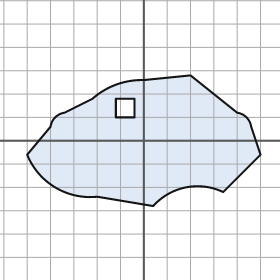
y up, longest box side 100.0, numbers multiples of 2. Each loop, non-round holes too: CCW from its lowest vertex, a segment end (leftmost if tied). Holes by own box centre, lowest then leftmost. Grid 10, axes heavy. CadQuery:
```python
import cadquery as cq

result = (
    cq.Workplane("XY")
    .moveTo(4.0, -28.0)
    .threePointArc((18.0, -20.0), (34.0, -22.0))
    .lineTo(50.0, -6.0)
    .lineTo(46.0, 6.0)
    .threePointArc((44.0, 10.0), (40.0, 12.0))
    .lineTo(20.0, 28.0)
    .lineTo(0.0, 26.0)
    .threePointArc((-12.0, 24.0), (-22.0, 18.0))
    .lineTo(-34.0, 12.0)
    .threePointArc((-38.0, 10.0), (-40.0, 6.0))
    .lineTo(-50.0, -6.0)
    .threePointArc((-38.0, -20.0), (-20.0, -24.0))
    .close()
    .moveTo(-12.0, 10.0)
    .lineTo(-4.0, 10.0)
    .lineTo(-4.0, 18.0)
    .lineTo(-12.0, 18.0)
    .close()
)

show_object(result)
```